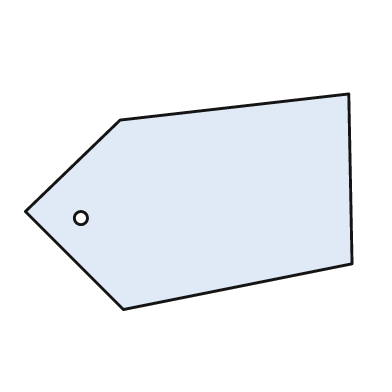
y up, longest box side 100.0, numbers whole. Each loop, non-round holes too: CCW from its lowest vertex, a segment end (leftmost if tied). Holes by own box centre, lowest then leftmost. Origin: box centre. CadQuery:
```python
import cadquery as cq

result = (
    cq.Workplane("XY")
    .moveTo(-20.0, -33.0)
    .lineTo(50.0, -19.0)
    .lineTo(49.0, 33.0)
    .lineTo(-21.0, 25.0)
    .lineTo(-50.0, -3.0)
    .close()
    .moveTo(-33.0, -5.0)
    .circle(2.0)
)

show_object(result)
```